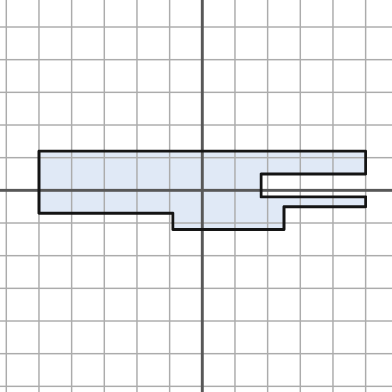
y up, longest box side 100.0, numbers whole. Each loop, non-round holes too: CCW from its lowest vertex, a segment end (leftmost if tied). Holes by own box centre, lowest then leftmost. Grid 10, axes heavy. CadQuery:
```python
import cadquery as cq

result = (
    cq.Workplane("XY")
    .moveTo(-9.0, -12.0)
    .lineTo(25.0, -12.0)
    .lineTo(25.0, -5.0)
    .lineTo(50.0, -5.0)
    .lineTo(50.0, -2.0)
    .lineTo(18.0, -2.0)
    .lineTo(18.0, 5.0)
    .lineTo(50.0, 5.0)
    .lineTo(50.0, 12.0)
    .lineTo(-50.0, 12.0)
    .lineTo(-50.0, -7.0)
    .lineTo(-9.0, -7.0)
    .close()
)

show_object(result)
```